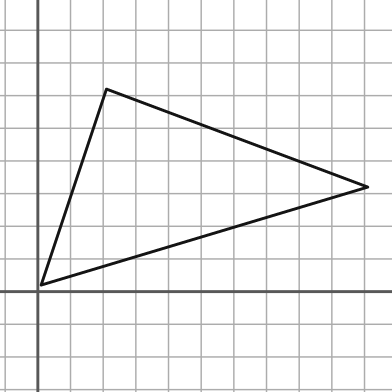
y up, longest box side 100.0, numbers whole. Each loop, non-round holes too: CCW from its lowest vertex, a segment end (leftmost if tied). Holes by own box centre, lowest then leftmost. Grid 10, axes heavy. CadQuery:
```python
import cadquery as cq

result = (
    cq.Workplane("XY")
    .moveTo(1.0, 2.0)
    .lineTo(101.0, 32.0)
    .lineTo(21.0, 62.0)
    .close()
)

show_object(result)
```